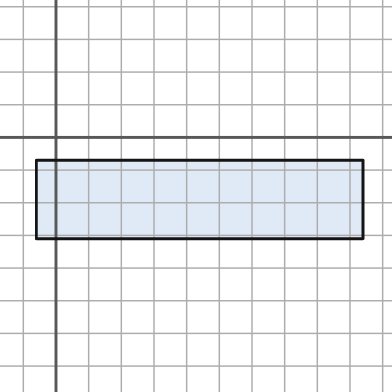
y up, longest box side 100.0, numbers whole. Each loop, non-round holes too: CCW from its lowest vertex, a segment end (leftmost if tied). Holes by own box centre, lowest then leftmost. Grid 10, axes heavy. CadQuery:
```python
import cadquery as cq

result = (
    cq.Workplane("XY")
    .moveTo(-6.0, -31.0)
    .lineTo(94.0, -31.0)
    .lineTo(94.0, -7.0)
    .lineTo(-6.0, -7.0)
    .close()
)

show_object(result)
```